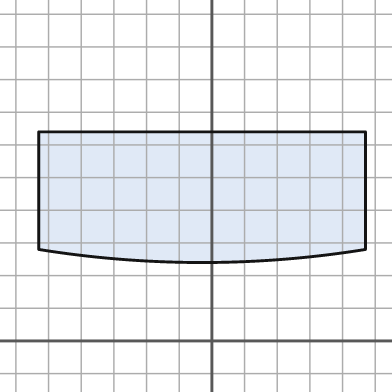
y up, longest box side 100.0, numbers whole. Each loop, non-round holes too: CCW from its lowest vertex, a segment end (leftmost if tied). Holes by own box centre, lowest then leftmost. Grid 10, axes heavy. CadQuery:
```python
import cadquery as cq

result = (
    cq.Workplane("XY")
    .moveTo(-53.0, 28.0)
    .threePointArc((-3.0, 24.0), (47.0, 28.0))
    .lineTo(47.0, 64.0)
    .lineTo(-53.0, 64.0)
    .close()
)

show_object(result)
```